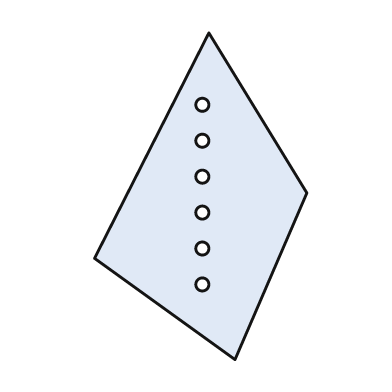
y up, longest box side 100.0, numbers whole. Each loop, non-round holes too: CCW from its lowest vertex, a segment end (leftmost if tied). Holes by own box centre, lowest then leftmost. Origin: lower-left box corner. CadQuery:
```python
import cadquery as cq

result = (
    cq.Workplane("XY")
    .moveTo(43.0, 0.0)
    .lineTo(65.0, 51.0)
    .lineTo(35.0, 100.0)
    .lineTo(0.0, 31.0)
    .close()
    .moveTo(33.0, 23.0)
    .circle(2.0)
    .moveTo(33.0, 34.0)
    .circle(2.0)
    .moveTo(33.0, 45.0)
    .circle(2.0)
    .moveTo(33.0, 56.0)
    .circle(2.0)
    .moveTo(33.0, 67.0)
    .circle(2.0)
    .moveTo(33.0, 78.0)
    .circle(2.0)
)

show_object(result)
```